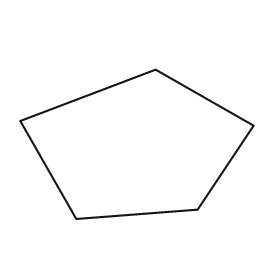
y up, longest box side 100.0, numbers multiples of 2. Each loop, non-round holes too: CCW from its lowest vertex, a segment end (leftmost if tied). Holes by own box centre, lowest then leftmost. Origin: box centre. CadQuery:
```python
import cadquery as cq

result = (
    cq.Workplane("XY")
    .moveTo(-26.0, -32.0)
    .lineTo(26.0, -28.0)
    .lineTo(50.0, 8.0)
    .lineTo(8.0, 32.0)
    .lineTo(-50.0, 10.0)
    .close()
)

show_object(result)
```